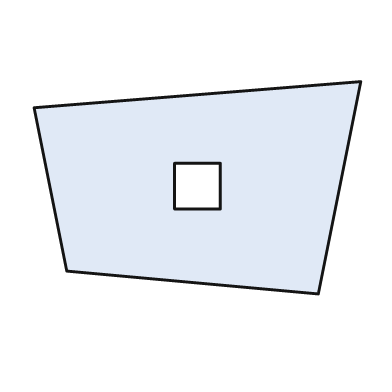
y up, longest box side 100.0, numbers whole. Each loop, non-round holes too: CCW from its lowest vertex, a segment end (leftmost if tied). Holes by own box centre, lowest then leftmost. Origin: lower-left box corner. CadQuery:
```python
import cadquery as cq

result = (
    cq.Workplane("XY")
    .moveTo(87.0, 0.0)
    .lineTo(100.0, 65.0)
    .lineTo(0.0, 57.0)
    .lineTo(10.0, 7.0)
    .close()
    .moveTo(43.0, 26.0)
    .lineTo(57.0, 26.0)
    .lineTo(57.0, 40.0)
    .lineTo(43.0, 40.0)
    .close()
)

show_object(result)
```